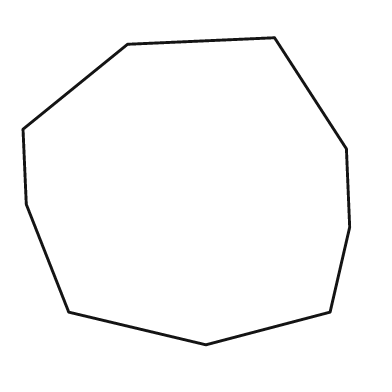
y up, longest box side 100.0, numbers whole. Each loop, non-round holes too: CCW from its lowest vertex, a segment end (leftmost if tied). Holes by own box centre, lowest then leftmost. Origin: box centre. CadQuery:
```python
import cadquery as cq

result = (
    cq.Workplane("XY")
    .moveTo(6.0, -47.0)
    .lineTo(44.0, -37.0)
    .lineTo(50.0, -11.0)
    .lineTo(49.0, 13.0)
    .lineTo(27.0, 47.0)
    .lineTo(-18.0, 45.0)
    .lineTo(-50.0, 19.0)
    .lineTo(-49.0, -4.0)
    .lineTo(-36.0, -37.0)
    .close()
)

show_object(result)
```